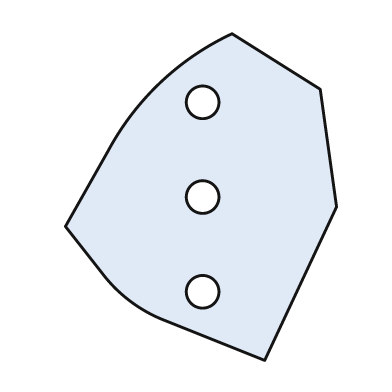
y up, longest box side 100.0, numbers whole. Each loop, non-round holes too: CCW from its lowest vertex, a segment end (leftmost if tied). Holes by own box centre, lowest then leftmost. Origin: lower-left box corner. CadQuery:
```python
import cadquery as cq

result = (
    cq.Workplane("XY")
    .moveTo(61.0, 0.0)
    .lineTo(83.0, 47.0)
    .lineTo(78.0, 83.0)
    .lineTo(51.0, 100.0)
    .threePointArc((29.0, 85.0), (13.0, 64.0))
    .lineTo(0.0, 41.0)
    .lineTo(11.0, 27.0)
    .threePointArc((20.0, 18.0), (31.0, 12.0))
    .close()
    .moveTo(42.0, 21.0)
    .circle(5.0)
    .moveTo(42.0, 50.0)
    .circle(5.0)
    .moveTo(42.0, 79.0)
    .circle(5.0)
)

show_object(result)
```